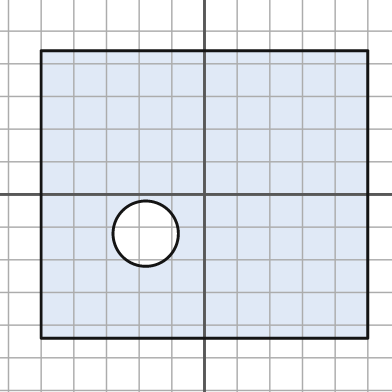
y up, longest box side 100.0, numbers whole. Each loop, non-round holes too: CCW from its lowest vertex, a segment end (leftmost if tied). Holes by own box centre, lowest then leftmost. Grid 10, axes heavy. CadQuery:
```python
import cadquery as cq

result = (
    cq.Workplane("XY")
    .moveTo(-50.0, -44.0)
    .lineTo(50.0, -44.0)
    .lineTo(50.0, 44.0)
    .lineTo(-50.0, 44.0)
    .close()
    .moveTo(-18.0, -12.0)
    .circle(10.0)
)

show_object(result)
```